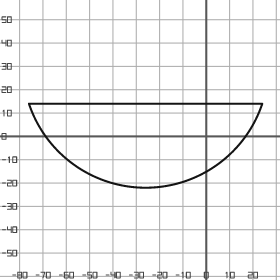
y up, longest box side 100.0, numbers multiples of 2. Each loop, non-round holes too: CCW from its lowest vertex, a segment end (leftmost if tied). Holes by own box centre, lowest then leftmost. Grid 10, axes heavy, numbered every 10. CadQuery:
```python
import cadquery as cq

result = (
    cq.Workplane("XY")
    .moveTo(-76.0, 14.0)
    .threePointArc((-26.0, -22.0), (24.0, 14.0))
    .close()
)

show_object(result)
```